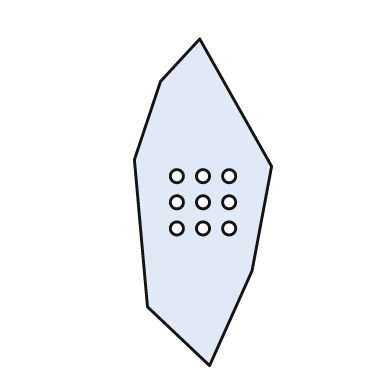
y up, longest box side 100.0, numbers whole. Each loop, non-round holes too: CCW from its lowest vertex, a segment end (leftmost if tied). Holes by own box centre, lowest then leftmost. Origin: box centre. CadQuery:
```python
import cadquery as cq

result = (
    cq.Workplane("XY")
    .moveTo(2.0, -50.0)
    .lineTo(15.0, -21.0)
    .lineTo(21.0, 11.0)
    .lineTo(-1.0, 50.0)
    .lineTo(-13.0, 37.0)
    .lineTo(-21.0, 13.0)
    .lineTo(-17.0, -32.0)
    .close()
    .moveTo(-8.0, -8.0)
    .circle(2.0)
    .moveTo(0.0, -8.0)
    .circle(2.0)
    .moveTo(8.0, -8.0)
    .circle(2.0)
    .moveTo(-8.0, 0.0)
    .circle(2.0)
    .moveTo(0.0, 0.0)
    .circle(2.0)
    .moveTo(8.0, 0.0)
    .circle(2.0)
    .moveTo(-8.0, 8.0)
    .circle(2.0)
    .moveTo(0.0, 8.0)
    .circle(2.0)
    .moveTo(8.0, 8.0)
    .circle(2.0)
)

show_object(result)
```